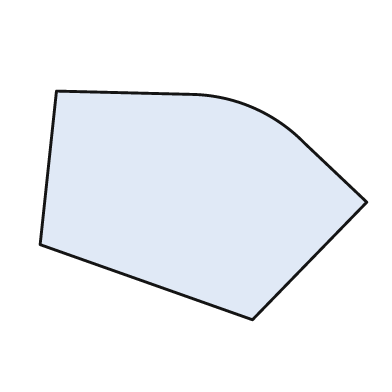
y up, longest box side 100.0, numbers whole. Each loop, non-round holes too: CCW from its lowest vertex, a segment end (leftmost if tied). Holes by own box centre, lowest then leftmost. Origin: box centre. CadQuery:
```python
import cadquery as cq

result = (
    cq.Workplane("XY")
    .moveTo(15.0, -35.0)
    .lineTo(50.0, 1.0)
    .lineTo(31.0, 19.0)
    .threePointArc((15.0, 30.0), (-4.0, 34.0))
    .lineTo(-45.0, 35.0)
    .lineTo(-50.0, -12.0)
    .close()
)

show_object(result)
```